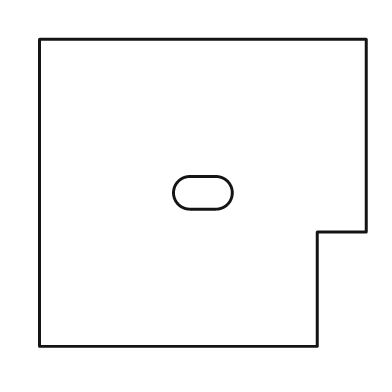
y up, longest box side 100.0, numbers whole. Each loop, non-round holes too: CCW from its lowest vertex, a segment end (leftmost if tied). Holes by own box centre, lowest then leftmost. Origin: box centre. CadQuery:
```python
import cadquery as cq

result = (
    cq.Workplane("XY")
    .moveTo(-50.0, -47.0)
    .lineTo(35.0, -47.0)
    .lineTo(35.0, -12.0)
    .lineTo(50.0, -12.0)
    .lineTo(50.0, 47.0)
    .lineTo(-50.0, 47.0)
    .close()
    .moveTo(-4.0, -5.0)
    .lineTo(4.0, -5.0)
    .threePointArc((9.0, 0.0), (4.0, 5.0))
    .lineTo(-4.0, 5.0)
    .threePointArc((-9.0, 0.0), (-4.0, -5.0))
    .close()
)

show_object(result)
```